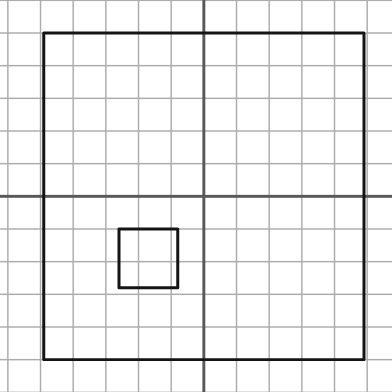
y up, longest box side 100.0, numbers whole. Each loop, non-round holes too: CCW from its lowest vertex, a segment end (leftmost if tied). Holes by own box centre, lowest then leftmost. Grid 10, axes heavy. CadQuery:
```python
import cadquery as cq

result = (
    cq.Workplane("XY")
    .moveTo(-49.0, -50.0)
    .lineTo(49.0, -50.0)
    .lineTo(49.0, 50.0)
    .lineTo(-49.0, 50.0)
    .close()
    .moveTo(-26.0, -28.0)
    .lineTo(-8.0, -28.0)
    .lineTo(-8.0, -10.0)
    .lineTo(-26.0, -10.0)
    .close()
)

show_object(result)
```